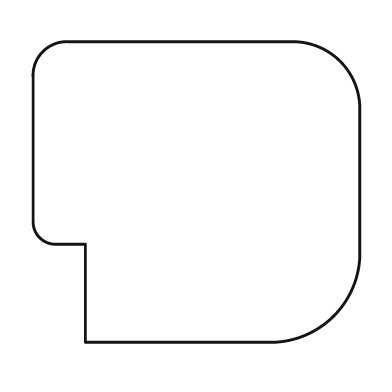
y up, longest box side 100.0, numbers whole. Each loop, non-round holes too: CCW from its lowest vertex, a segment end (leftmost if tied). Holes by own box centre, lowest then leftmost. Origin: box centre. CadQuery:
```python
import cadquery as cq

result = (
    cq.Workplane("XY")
    .moveTo(-34.0, -46.0)
    .lineTo(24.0, -46.0)
    .threePointArc((42.0, -38.0), (50.0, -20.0))
    .lineTo(50.0, 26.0)
    .threePointArc((44.0, 40.0), (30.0, 46.0))
    .lineTo(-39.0, 46.0)
    .threePointArc((-47.0, 43.0), (-50.0, 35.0))
    .lineTo(-50.0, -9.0)
    .threePointArc((-48.0, -14.0), (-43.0, -16.0))
    .lineTo(-34.0, -16.0)
    .close()
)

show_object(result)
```